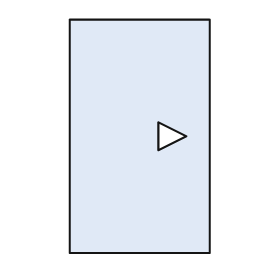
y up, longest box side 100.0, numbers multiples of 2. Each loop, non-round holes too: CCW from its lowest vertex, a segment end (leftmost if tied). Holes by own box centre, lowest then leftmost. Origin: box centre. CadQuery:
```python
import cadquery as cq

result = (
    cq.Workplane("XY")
    .moveTo(-30.0, -50.0)
    .lineTo(30.0, -50.0)
    .lineTo(30.0, 50.0)
    .lineTo(-30.0, 50.0)
    .close()
    .moveTo(8.0, -6.0)
    .lineTo(20.0, 0.0)
    .lineTo(8.0, 6.0)
    .close()
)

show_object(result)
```